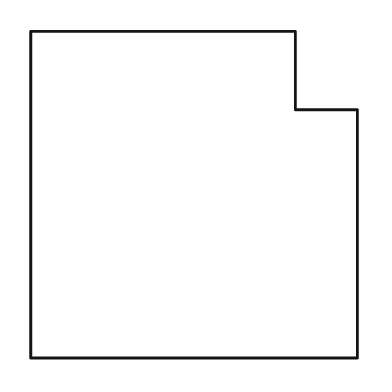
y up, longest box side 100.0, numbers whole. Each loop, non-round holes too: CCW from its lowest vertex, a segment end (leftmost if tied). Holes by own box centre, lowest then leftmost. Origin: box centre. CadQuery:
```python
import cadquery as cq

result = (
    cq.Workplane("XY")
    .moveTo(-50.0, -50.0)
    .lineTo(50.0, -50.0)
    .lineTo(50.0, 26.0)
    .lineTo(31.0, 26.0)
    .lineTo(31.0, 50.0)
    .lineTo(-50.0, 50.0)
    .close()
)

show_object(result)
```